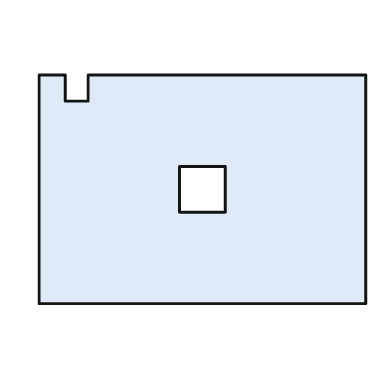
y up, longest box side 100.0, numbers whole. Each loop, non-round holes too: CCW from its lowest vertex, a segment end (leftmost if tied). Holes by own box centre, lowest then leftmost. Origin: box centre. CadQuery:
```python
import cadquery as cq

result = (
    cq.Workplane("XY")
    .moveTo(-50.0, -35.0)
    .lineTo(50.0, -35.0)
    .lineTo(50.0, 35.0)
    .lineTo(-35.0, 35.0)
    .lineTo(-35.0, 27.0)
    .lineTo(-42.0, 27.0)
    .lineTo(-42.0, 35.0)
    .lineTo(-50.0, 35.0)
    .close()
    .moveTo(-7.0, -7.0)
    .lineTo(7.0, -7.0)
    .lineTo(7.0, 7.0)
    .lineTo(-7.0, 7.0)
    .close()
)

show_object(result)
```